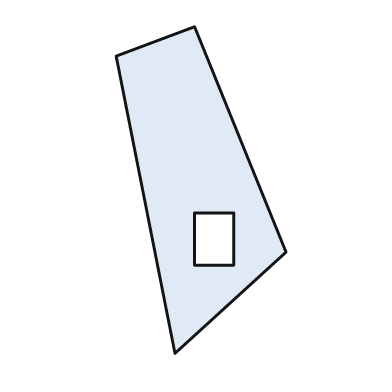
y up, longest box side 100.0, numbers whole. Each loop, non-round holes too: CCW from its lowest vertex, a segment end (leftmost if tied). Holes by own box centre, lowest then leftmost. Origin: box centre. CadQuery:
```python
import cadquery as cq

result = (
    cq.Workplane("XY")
    .moveTo(-8.0, -50.0)
    .lineTo(26.0, -19.0)
    .lineTo(-2.0, 50.0)
    .lineTo(-26.0, 41.0)
    .close()
    .moveTo(-2.0, -23.0)
    .lineTo(10.0, -23.0)
    .lineTo(10.0, -7.0)
    .lineTo(-2.0, -7.0)
    .close()
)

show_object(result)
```